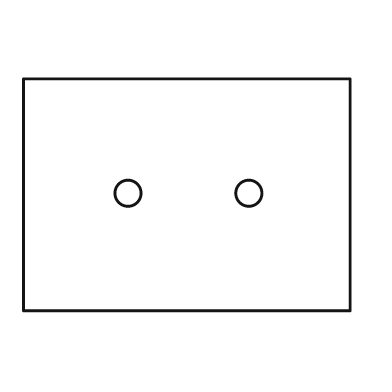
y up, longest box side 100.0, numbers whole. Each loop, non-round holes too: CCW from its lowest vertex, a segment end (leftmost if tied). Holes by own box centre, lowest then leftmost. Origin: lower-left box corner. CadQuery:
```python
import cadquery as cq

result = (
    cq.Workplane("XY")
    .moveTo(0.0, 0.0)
    .lineTo(100.0, 0.0)
    .lineTo(100.0, 71.0)
    .lineTo(0.0, 71.0)
    .close()
    .moveTo(32.0, 36.0)
    .circle(4.0)
    .moveTo(69.0, 36.0)
    .circle(4.0)
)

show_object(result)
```